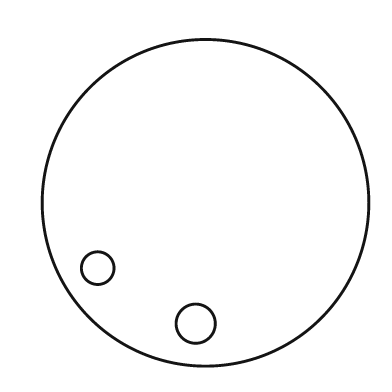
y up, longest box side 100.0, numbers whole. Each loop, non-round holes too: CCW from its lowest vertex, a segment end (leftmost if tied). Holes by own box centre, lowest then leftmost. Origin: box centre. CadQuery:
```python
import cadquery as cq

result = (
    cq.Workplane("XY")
    .moveTo(0.0, 0.0)
    .circle(50.0)
    .moveTo(-3.0, -37.0)
    .circle(6.0)
    .moveTo(-33.0, -20.0)
    .circle(5.0)
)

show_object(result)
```